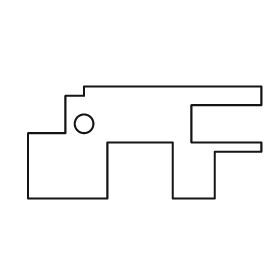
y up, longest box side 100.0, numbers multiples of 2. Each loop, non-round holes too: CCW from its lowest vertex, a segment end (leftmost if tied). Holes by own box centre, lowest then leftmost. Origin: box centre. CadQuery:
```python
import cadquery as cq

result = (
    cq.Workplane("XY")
    .moveTo(-50.0, -24.0)
    .lineTo(-16.0, -24.0)
    .lineTo(-16.0, 0.0)
    .lineTo(12.0, 0.0)
    .lineTo(12.0, -24.0)
    .lineTo(30.0, -24.0)
    .lineTo(30.0, -4.0)
    .lineTo(50.0, -4.0)
    .lineTo(50.0, 0.0)
    .lineTo(20.0, 0.0)
    .lineTo(20.0, 16.0)
    .lineTo(50.0, 16.0)
    .lineTo(50.0, 24.0)
    .lineTo(-26.0, 24.0)
    .lineTo(-26.0, 20.0)
    .lineTo(-34.0, 20.0)
    .lineTo(-34.0, 4.0)
    .lineTo(-50.0, 4.0)
    .close()
    .moveTo(-26.0, 8.0)
    .circle(4.0)
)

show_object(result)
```